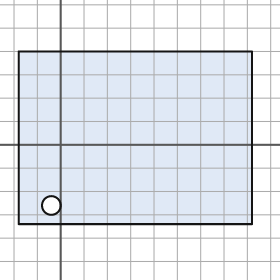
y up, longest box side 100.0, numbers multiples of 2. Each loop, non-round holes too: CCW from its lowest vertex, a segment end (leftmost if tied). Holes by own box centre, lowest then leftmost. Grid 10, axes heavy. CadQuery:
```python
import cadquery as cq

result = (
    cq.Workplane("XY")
    .moveTo(-18.0, -34.0)
    .lineTo(82.0, -34.0)
    .lineTo(82.0, 40.0)
    .lineTo(-18.0, 40.0)
    .close()
    .moveTo(-4.0, -26.0)
    .circle(4.0)
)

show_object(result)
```